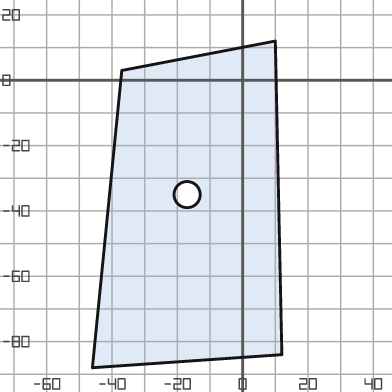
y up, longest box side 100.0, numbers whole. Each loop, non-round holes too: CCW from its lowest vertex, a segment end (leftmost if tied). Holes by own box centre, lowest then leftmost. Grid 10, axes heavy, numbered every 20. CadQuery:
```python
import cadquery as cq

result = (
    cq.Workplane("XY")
    .moveTo(-46.0, -88.0)
    .lineTo(12.0, -84.0)
    .lineTo(10.0, 12.0)
    .lineTo(-37.0, 3.0)
    .close()
    .moveTo(-17.0, -35.0)
    .circle(4.0)
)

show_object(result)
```